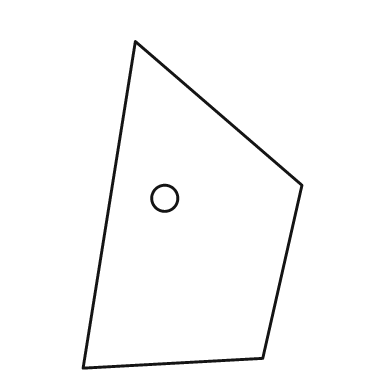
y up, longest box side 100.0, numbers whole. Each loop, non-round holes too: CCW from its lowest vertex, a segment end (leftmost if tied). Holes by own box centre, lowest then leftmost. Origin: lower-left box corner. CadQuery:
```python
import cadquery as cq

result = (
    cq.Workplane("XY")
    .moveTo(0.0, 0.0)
    .lineTo(55.0, 3.0)
    .lineTo(67.0, 56.0)
    .lineTo(16.0, 100.0)
    .close()
    .moveTo(25.0, 52.0)
    .circle(4.0)
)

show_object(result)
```